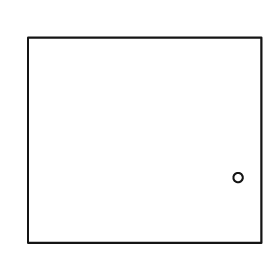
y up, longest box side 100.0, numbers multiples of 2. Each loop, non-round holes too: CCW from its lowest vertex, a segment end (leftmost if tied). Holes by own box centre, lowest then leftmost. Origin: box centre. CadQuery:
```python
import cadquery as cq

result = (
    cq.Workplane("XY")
    .moveTo(-50.0, -44.0)
    .lineTo(50.0, -44.0)
    .lineTo(50.0, 44.0)
    .lineTo(-50.0, 44.0)
    .close()
    .moveTo(40.0, -16.0)
    .circle(2.0)
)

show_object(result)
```